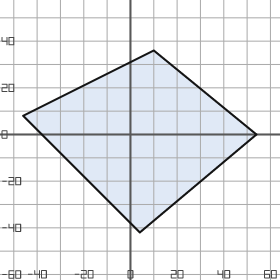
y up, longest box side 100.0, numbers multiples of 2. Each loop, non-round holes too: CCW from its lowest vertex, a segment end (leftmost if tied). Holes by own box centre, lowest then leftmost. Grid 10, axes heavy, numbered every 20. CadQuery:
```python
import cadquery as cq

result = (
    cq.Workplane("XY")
    .moveTo(4.0, -42.0)
    .lineTo(54.0, 0.0)
    .lineTo(10.0, 36.0)
    .lineTo(-46.0, 8.0)
    .close()
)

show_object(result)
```